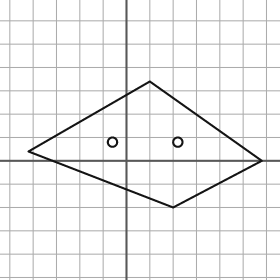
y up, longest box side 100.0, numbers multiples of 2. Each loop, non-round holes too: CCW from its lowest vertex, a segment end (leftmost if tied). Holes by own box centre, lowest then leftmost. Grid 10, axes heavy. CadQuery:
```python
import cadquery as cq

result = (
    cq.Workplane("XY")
    .moveTo(20.0, -20.0)
    .lineTo(58.0, 0.0)
    .lineTo(10.0, 34.0)
    .lineTo(-42.0, 4.0)
    .close()
    .moveTo(-6.0, 8.0)
    .circle(2.0)
    .moveTo(22.0, 8.0)
    .circle(2.0)
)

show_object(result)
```